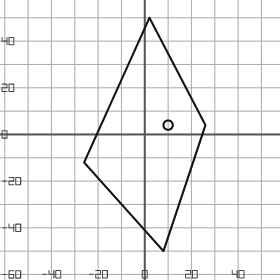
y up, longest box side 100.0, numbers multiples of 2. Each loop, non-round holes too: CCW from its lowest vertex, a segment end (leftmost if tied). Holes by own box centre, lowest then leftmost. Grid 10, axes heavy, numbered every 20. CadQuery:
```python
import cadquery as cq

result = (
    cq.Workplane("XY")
    .moveTo(8.0, -50.0)
    .lineTo(26.0, 4.0)
    .lineTo(2.0, 50.0)
    .lineTo(-26.0, -12.0)
    .close()
    .moveTo(10.0, 4.0)
    .circle(2.0)
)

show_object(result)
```